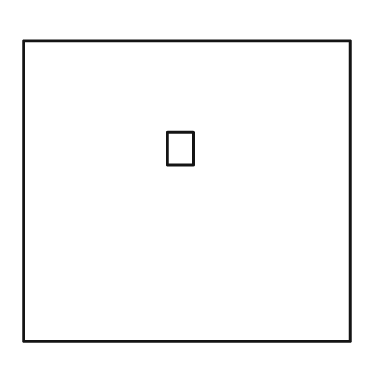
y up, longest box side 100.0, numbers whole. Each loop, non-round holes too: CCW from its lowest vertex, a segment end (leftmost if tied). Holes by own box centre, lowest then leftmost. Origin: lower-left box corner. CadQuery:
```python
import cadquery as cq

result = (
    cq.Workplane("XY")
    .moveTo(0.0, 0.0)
    .lineTo(100.0, 0.0)
    .lineTo(100.0, 92.0)
    .lineTo(0.0, 92.0)
    .close()
    .moveTo(44.0, 54.0)
    .lineTo(52.0, 54.0)
    .lineTo(52.0, 64.0)
    .lineTo(44.0, 64.0)
    .close()
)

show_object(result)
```